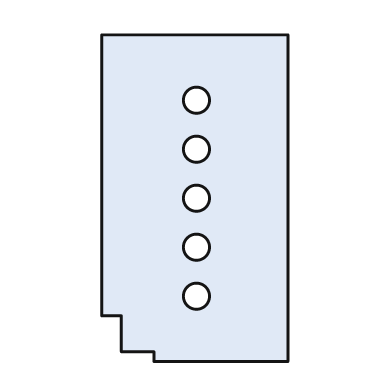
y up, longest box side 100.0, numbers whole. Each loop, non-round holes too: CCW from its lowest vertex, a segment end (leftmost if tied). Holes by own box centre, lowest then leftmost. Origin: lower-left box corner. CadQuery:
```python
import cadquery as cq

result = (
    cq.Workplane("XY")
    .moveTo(16.0, 0.0)
    .lineTo(57.0, 0.0)
    .lineTo(57.0, 100.0)
    .lineTo(0.0, 100.0)
    .lineTo(0.0, 14.0)
    .lineTo(6.0, 14.0)
    .lineTo(6.0, 3.0)
    .lineTo(16.0, 3.0)
    .close()
    .moveTo(29.0, 20.0)
    .circle(4.0)
    .moveTo(29.0, 35.0)
    .circle(4.0)
    .moveTo(29.0, 50.0)
    .circle(4.0)
    .moveTo(29.0, 65.0)
    .circle(4.0)
    .moveTo(29.0, 80.0)
    .circle(4.0)
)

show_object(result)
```